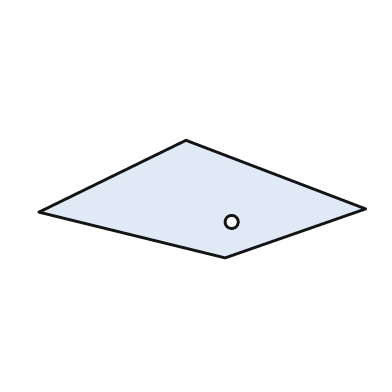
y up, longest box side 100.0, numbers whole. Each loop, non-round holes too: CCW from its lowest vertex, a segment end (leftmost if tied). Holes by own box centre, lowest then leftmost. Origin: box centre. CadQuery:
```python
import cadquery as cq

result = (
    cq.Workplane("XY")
    .moveTo(7.0, -18.0)
    .lineTo(50.0, -3.0)
    .lineTo(-5.0, 18.0)
    .lineTo(-50.0, -4.0)
    .close()
    .moveTo(9.0, -7.0)
    .circle(2.0)
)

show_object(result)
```